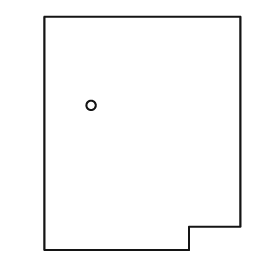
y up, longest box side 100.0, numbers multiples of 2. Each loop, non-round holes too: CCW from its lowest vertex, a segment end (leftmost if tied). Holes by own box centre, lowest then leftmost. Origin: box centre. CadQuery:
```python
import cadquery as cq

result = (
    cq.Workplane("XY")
    .moveTo(-42.0, -50.0)
    .lineTo(20.0, -50.0)
    .lineTo(20.0, -40.0)
    .lineTo(42.0, -40.0)
    .lineTo(42.0, 50.0)
    .lineTo(-42.0, 50.0)
    .close()
    .moveTo(-22.0, 12.0)
    .circle(2.0)
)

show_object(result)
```